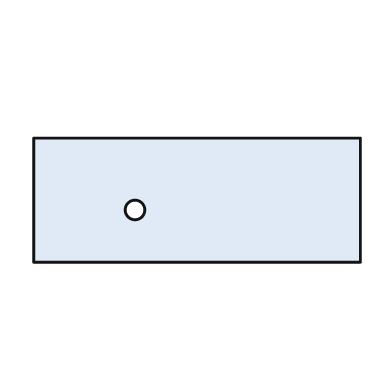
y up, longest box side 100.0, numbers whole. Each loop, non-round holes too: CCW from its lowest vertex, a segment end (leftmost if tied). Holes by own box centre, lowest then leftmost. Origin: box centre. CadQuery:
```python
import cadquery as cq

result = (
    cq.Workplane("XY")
    .moveTo(-50.0, -19.0)
    .lineTo(50.0, -19.0)
    .lineTo(50.0, 19.0)
    .lineTo(-50.0, 19.0)
    .close()
    .moveTo(-19.0, -3.0)
    .circle(3.0)
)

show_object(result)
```